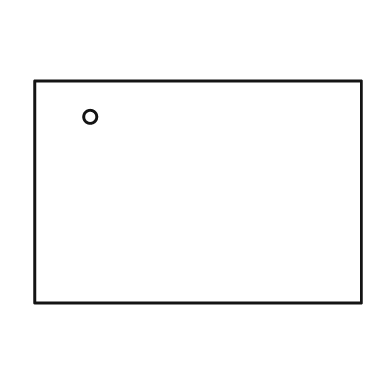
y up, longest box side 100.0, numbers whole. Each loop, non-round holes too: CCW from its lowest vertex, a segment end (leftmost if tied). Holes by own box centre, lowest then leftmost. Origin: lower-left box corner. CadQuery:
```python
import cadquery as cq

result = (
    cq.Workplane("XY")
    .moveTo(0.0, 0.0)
    .lineTo(100.0, 0.0)
    .lineTo(100.0, 68.0)
    .lineTo(0.0, 68.0)
    .close()
    .moveTo(17.0, 57.0)
    .circle(2.0)
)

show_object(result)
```